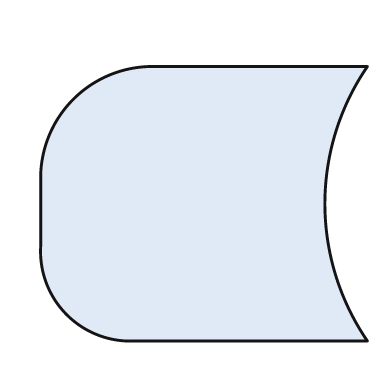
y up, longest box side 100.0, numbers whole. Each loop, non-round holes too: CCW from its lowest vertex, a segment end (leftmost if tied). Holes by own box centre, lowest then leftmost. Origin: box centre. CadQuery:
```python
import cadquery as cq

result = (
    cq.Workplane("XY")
    .moveTo(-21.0, -42.0)
    .lineTo(50.0, -42.0)
    .threePointArc((37.0, 0.0), (50.0, 42.0))
    .lineTo(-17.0, 42.0)
    .threePointArc((-40.0, 32.0), (-50.0, 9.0))
    .lineTo(-50.0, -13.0)
    .threePointArc((-42.0, -34.0), (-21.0, -42.0))
    .close()
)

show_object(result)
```